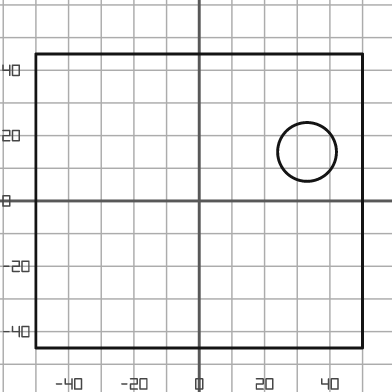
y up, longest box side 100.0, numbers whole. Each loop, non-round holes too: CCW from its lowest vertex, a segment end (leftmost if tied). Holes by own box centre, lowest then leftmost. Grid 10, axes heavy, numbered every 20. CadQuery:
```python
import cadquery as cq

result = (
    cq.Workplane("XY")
    .moveTo(-50.0, -45.0)
    .lineTo(50.0, -45.0)
    .lineTo(50.0, 45.0)
    .lineTo(-50.0, 45.0)
    .close()
    .moveTo(33.0, 15.0)
    .circle(9.0)
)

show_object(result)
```